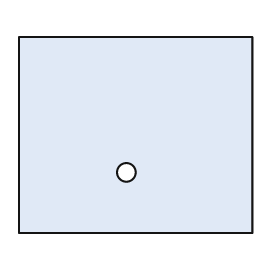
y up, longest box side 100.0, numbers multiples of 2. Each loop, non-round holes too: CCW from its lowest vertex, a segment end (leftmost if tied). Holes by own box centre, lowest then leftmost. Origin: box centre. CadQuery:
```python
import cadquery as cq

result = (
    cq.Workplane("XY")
    .moveTo(-50.0, -42.0)
    .lineTo(50.0, -42.0)
    .lineTo(50.0, 42.0)
    .lineTo(-50.0, 42.0)
    .close()
    .moveTo(-4.0, -16.0)
    .circle(4.0)
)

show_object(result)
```